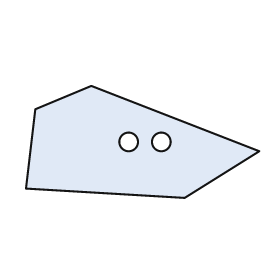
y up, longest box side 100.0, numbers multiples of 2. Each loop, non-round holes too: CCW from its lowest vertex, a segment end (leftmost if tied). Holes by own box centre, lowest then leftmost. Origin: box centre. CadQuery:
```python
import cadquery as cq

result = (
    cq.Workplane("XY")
    .moveTo(18.0, -24.0)
    .lineTo(50.0, -4.0)
    .lineTo(-22.0, 24.0)
    .lineTo(-46.0, 14.0)
    .lineTo(-50.0, -20.0)
    .close()
    .moveTo(-6.0, 0.0)
    .circle(4.0)
    .moveTo(8.0, 0.0)
    .circle(4.0)
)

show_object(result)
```